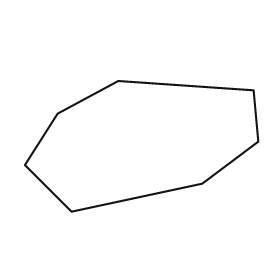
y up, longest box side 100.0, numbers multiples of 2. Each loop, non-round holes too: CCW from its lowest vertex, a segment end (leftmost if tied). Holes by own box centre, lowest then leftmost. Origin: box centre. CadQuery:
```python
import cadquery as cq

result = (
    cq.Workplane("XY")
    .moveTo(-30.0, -28.0)
    .lineTo(26.0, -16.0)
    .lineTo(50.0, 2.0)
    .lineTo(48.0, 24.0)
    .lineTo(-10.0, 28.0)
    .lineTo(-36.0, 14.0)
    .lineTo(-50.0, -8.0)
    .close()
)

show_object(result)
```